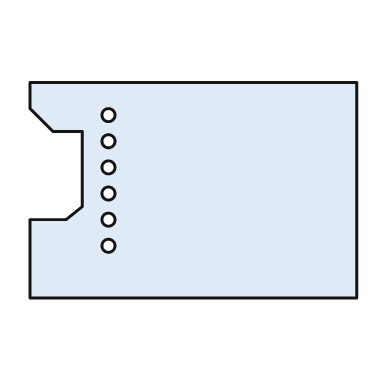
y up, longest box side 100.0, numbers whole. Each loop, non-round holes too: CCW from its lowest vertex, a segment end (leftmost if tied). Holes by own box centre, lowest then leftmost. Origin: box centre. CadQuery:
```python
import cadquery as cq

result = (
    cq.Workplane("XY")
    .moveTo(-50.0, -33.0)
    .lineTo(50.0, -33.0)
    .lineTo(50.0, 33.0)
    .lineTo(-50.0, 33.0)
    .lineTo(-50.0, 25.0)
    .lineTo(-43.0, 18.0)
    .lineTo(-34.0, 18.0)
    .lineTo(-34.0, -5.0)
    .lineTo(-39.0, -9.0)
    .lineTo(-50.0, -9.0)
    .close()
    .moveTo(-26.0, -17.0)
    .circle(2.0)
    .moveTo(-26.0, -9.0)
    .circle(2.0)
    .moveTo(-26.0, -1.0)
    .circle(2.0)
    .moveTo(-26.0, 7.0)
    .circle(2.0)
    .moveTo(-26.0, 15.0)
    .circle(2.0)
    .moveTo(-26.0, 23.0)
    .circle(2.0)
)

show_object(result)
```